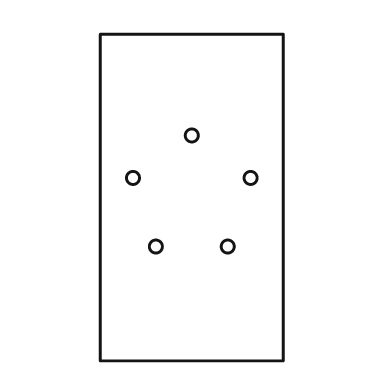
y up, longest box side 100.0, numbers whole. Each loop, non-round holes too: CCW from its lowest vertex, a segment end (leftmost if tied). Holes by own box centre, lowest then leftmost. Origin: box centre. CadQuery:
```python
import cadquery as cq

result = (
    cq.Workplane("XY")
    .moveTo(-28.0, -50.0)
    .lineTo(28.0, -50.0)
    .lineTo(28.0, 50.0)
    .lineTo(-28.0, 50.0)
    .close()
    .moveTo(-11.0, -15.0)
    .circle(2.0)
    .moveTo(11.0, -15.0)
    .circle(2.0)
    .moveTo(-18.0, 6.0)
    .circle(2.0)
    .moveTo(18.0, 6.0)
    .circle(2.0)
    .moveTo(0.0, 19.0)
    .circle(2.0)
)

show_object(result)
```